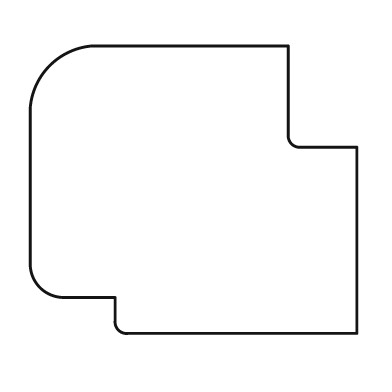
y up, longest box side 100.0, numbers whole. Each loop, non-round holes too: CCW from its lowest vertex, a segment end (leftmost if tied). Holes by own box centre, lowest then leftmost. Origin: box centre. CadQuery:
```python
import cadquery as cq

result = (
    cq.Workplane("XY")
    .moveTo(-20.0, -44.0)
    .lineTo(50.0, -44.0)
    .lineTo(50.0, 13.0)
    .lineTo(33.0, 13.0)
    .threePointArc((30.0, 14.0), (29.0, 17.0))
    .lineTo(29.0, 44.0)
    .lineTo(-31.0, 44.0)
    .threePointArc((-44.0, 38.0), (-50.0, 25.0))
    .lineTo(-50.0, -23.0)
    .threePointArc((-47.0, -30.0), (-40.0, -33.0))
    .lineTo(-24.0, -33.0)
    .lineTo(-24.0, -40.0)
    .threePointArc((-23.0, -43.0), (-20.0, -44.0))
    .close()
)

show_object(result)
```